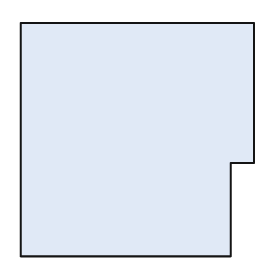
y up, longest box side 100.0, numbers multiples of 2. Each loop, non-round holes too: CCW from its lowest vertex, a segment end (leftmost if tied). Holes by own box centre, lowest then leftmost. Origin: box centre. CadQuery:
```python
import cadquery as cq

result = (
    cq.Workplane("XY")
    .moveTo(-50.0, -50.0)
    .lineTo(40.0, -50.0)
    .lineTo(40.0, -10.0)
    .lineTo(50.0, -10.0)
    .lineTo(50.0, 50.0)
    .lineTo(-50.0, 50.0)
    .close()
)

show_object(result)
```